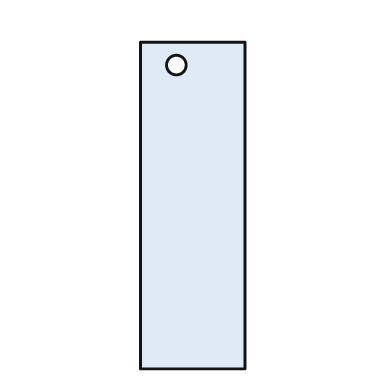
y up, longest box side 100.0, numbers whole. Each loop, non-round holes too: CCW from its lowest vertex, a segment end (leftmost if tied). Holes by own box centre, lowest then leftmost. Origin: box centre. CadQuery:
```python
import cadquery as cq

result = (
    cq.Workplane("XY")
    .moveTo(-16.0, -50.0)
    .lineTo(16.0, -50.0)
    .lineTo(16.0, 50.0)
    .lineTo(-16.0, 50.0)
    .close()
    .moveTo(-5.0, 43.0)
    .circle(3.0)
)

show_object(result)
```